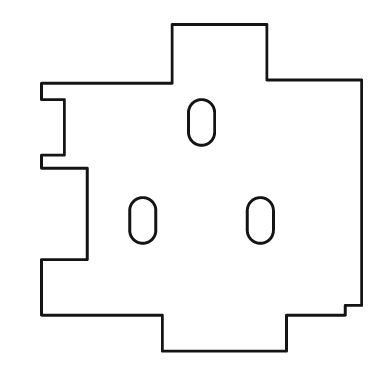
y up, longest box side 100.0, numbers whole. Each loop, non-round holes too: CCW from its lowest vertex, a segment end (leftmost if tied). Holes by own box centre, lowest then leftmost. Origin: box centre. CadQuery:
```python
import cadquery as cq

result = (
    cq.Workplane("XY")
    .moveTo(-12.0, -50.0)
    .lineTo(26.0, -50.0)
    .lineTo(26.0, -39.0)
    .lineTo(44.0, -39.0)
    .lineTo(44.0, -36.0)
    .lineTo(49.0, -36.0)
    .lineTo(49.0, 33.0)
    .lineTo(20.0, 33.0)
    .lineTo(20.0, 50.0)
    .lineTo(-9.0, 50.0)
    .lineTo(-9.0, 32.0)
    .lineTo(-49.0, 32.0)
    .lineTo(-49.0, 27.0)
    .lineTo(-42.0, 27.0)
    .lineTo(-42.0, 10.0)
    .lineTo(-49.0, 10.0)
    .lineTo(-49.0, 6.0)
    .lineTo(-35.0, 6.0)
    .lineTo(-35.0, -22.0)
    .lineTo(-49.0, -22.0)
    .lineTo(-49.0, -39.0)
    .lineTo(-12.0, -39.0)
    .close()
    .moveTo(-22.0, -13.0)
    .threePointArc((-18.0, -17.0), (-14.0, -13.0))
    .lineTo(-14.0, -7.0)
    .threePointArc((-18.0, -3.0), (-22.0, -7.0))
    .close()
    .moveTo(14.0, -13.0)
    .threePointArc((18.0, -17.0), (22.0, -13.0))
    .lineTo(22.0, -7.0)
    .threePointArc((18.0, -3.0), (14.0, -7.0))
    .close()
    .moveTo(-4.0, 17.0)
    .threePointArc((0.0, 13.0), (4.0, 17.0))
    .lineTo(4.0, 23.0)
    .threePointArc((0.0, 27.0), (-4.0, 23.0))
    .close()
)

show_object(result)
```